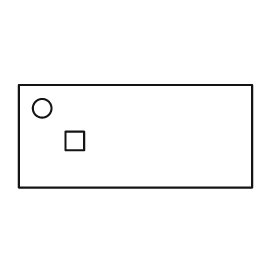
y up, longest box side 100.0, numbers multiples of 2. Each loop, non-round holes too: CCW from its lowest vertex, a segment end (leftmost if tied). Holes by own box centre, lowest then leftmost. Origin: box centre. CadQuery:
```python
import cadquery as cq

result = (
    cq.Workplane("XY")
    .moveTo(-50.0, -22.0)
    .lineTo(50.0, -22.0)
    .lineTo(50.0, 22.0)
    .lineTo(-50.0, 22.0)
    .close()
    .moveTo(-30.0, -6.0)
    .lineTo(-22.0, -6.0)
    .lineTo(-22.0, 2.0)
    .lineTo(-30.0, 2.0)
    .close()
    .moveTo(-40.0, 12.0)
    .circle(4.0)
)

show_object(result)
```